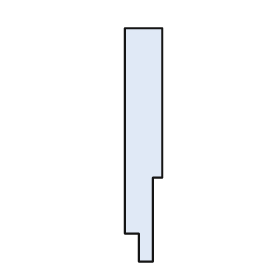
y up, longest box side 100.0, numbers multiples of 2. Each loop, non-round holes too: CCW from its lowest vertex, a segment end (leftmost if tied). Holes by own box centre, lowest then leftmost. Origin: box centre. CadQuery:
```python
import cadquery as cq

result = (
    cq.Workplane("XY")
    .moveTo(-2.0, -50.0)
    .lineTo(4.0, -50.0)
    .lineTo(4.0, -14.0)
    .lineTo(8.0, -14.0)
    .lineTo(8.0, 50.0)
    .lineTo(-8.0, 50.0)
    .lineTo(-8.0, -38.0)
    .lineTo(-2.0, -38.0)
    .close()
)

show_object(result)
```